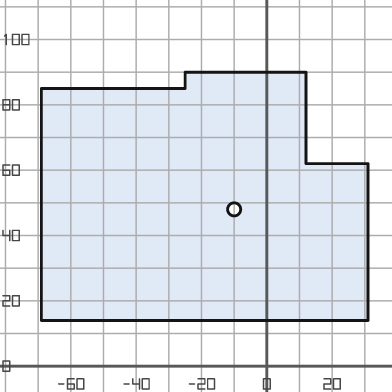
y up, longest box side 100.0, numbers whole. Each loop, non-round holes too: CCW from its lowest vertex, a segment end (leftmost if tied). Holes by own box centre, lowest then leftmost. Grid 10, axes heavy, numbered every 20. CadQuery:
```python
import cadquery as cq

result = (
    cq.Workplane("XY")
    .moveTo(-69.0, 14.0)
    .lineTo(31.0, 14.0)
    .lineTo(31.0, 62.0)
    .lineTo(12.0, 62.0)
    .lineTo(12.0, 90.0)
    .lineTo(-25.0, 90.0)
    .lineTo(-25.0, 85.0)
    .lineTo(-69.0, 85.0)
    .close()
    .moveTo(-10.0, 48.0)
    .circle(2.0)
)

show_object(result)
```